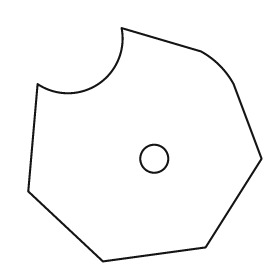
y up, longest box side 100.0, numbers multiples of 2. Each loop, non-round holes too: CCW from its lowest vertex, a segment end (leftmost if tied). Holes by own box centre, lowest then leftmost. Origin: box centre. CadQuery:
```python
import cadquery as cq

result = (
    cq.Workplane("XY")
    .moveTo(-18.0, -50.0)
    .lineTo(26.0, -44.0)
    .lineTo(50.0, -6.0)
    .lineTo(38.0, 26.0)
    .threePointArc((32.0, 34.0), (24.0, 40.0))
    .lineTo(-10.0, 50.0)
    .threePointArc((-20.0, 26.0), (-46.0, 26.0))
    .lineTo(-50.0, -20.0)
    .close()
    .moveTo(4.0, -6.0)
    .circle(6.0)
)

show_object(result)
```